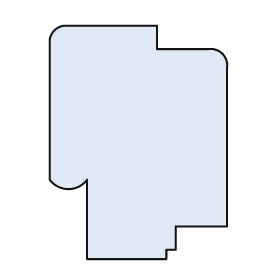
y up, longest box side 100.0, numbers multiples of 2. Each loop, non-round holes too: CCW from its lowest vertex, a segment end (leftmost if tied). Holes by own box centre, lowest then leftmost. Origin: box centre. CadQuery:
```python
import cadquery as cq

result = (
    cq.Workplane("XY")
    .moveTo(-22.0, -50.0)
    .lineTo(12.0, -50.0)
    .lineTo(12.0, -46.0)
    .lineTo(16.0, -46.0)
    .lineTo(16.0, -36.0)
    .lineTo(38.0, -36.0)
    .lineTo(38.0, 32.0)
    .threePointArc((36.0, 38.0), (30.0, 40.0))
    .lineTo(8.0, 40.0)
    .lineTo(8.0, 50.0)
    .lineTo(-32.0, 50.0)
    .threePointArc((-36.0, 48.0), (-38.0, 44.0))
    .lineTo(-38.0, -16.0)
    .threePointArc((-30.0, -20.0), (-22.0, -16.0))
    .close()
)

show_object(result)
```